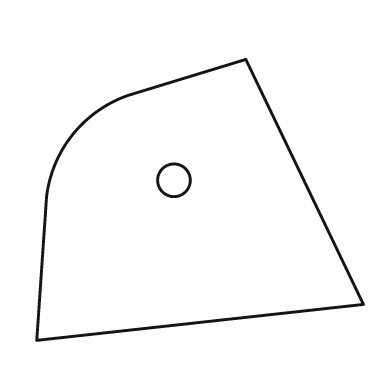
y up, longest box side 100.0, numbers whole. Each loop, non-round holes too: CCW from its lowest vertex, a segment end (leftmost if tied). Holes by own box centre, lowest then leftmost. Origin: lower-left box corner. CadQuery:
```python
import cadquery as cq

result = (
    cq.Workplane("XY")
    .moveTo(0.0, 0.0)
    .lineTo(100.0, 11.0)
    .lineTo(64.0, 86.0)
    .lineTo(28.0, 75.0)
    .threePointArc((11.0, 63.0), (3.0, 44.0))
    .close()
    .moveTo(42.0, 49.0)
    .circle(5.0)
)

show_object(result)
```